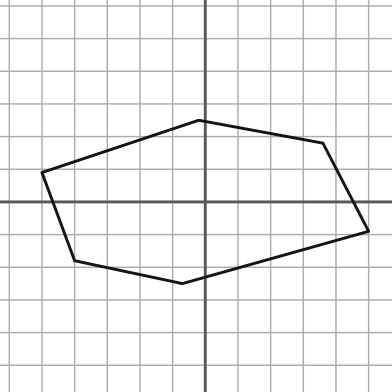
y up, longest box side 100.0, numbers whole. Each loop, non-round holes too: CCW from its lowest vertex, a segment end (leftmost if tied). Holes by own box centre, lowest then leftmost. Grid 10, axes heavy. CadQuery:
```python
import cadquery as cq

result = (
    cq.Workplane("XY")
    .moveTo(-7.0, -25.0)
    .lineTo(50.0, -9.0)
    .lineTo(36.0, 18.0)
    .lineTo(-2.0, 25.0)
    .lineTo(-50.0, 9.0)
    .lineTo(-40.0, -18.0)
    .close()
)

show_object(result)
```